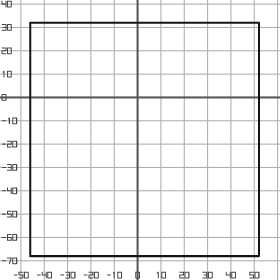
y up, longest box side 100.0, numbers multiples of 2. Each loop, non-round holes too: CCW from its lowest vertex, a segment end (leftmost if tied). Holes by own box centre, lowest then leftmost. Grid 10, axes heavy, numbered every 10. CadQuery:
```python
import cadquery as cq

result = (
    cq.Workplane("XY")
    .moveTo(-46.0, -68.0)
    .lineTo(52.0, -68.0)
    .lineTo(52.0, 32.0)
    .lineTo(-46.0, 32.0)
    .close()
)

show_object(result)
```